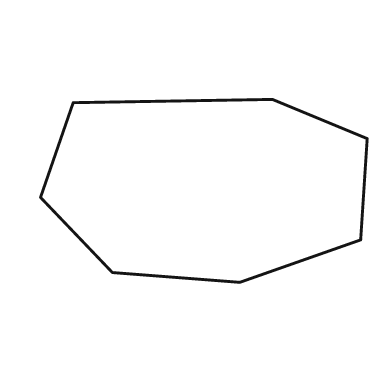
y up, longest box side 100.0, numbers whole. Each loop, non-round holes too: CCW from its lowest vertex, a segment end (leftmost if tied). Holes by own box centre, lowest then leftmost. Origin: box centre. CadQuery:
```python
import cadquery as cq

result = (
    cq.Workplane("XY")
    .moveTo(11.0, -28.0)
    .lineTo(48.0, -15.0)
    .lineTo(50.0, 16.0)
    .lineTo(21.0, 28.0)
    .lineTo(-40.0, 27.0)
    .lineTo(-50.0, -2.0)
    .lineTo(-28.0, -25.0)
    .close()
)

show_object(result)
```